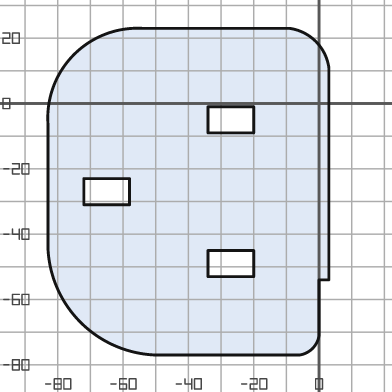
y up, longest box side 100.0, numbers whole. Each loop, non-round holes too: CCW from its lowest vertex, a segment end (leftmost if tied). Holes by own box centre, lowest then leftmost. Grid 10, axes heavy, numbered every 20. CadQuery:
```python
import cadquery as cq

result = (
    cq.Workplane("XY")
    .moveTo(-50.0, -77.0)
    .lineTo(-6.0, -77.0)
    .threePointArc((-2.0, -75.0), (0.0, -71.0))
    .lineTo(0.0, -54.0)
    .lineTo(3.0, -54.0)
    .lineTo(3.0, 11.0)
    .threePointArc((-1.0, 19.0), (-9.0, 23.0))
    .lineTo(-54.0, 23.0)
    .threePointArc((-75.0, 15.0), (-83.0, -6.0))
    .lineTo(-83.0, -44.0)
    .threePointArc((-73.0, -67.0), (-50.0, -77.0))
    .close()
    .moveTo(-34.0, -53.0)
    .lineTo(-20.0, -53.0)
    .lineTo(-20.0, -45.0)
    .lineTo(-34.0, -45.0)
    .close()
    .moveTo(-72.0, -31.0)
    .lineTo(-58.0, -31.0)
    .lineTo(-58.0, -23.0)
    .lineTo(-72.0, -23.0)
    .close()
    .moveTo(-34.0, -9.0)
    .lineTo(-20.0, -9.0)
    .lineTo(-20.0, -1.0)
    .lineTo(-34.0, -1.0)
    .close()
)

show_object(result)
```